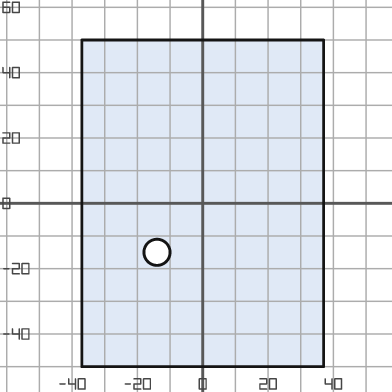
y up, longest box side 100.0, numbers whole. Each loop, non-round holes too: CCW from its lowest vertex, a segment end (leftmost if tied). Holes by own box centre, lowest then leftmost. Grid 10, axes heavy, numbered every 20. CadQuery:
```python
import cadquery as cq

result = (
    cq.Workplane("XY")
    .moveTo(-37.0, -50.0)
    .lineTo(37.0, -50.0)
    .lineTo(37.0, 50.0)
    .lineTo(-37.0, 50.0)
    .close()
    .moveTo(-14.0, -15.0)
    .circle(4.0)
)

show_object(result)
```